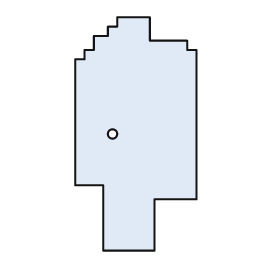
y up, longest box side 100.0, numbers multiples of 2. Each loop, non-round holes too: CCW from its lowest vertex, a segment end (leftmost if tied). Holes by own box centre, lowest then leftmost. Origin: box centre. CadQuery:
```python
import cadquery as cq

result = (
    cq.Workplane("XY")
    .moveTo(-14.0, -50.0)
    .lineTo(8.0, -50.0)
    .lineTo(8.0, -28.0)
    .lineTo(26.0, -28.0)
    .lineTo(26.0, 36.0)
    .lineTo(22.0, 36.0)
    .lineTo(22.0, 40.0)
    .lineTo(6.0, 40.0)
    .lineTo(6.0, 50.0)
    .lineTo(-8.0, 50.0)
    .lineTo(-8.0, 46.0)
    .lineTo(-12.0, 46.0)
    .lineTo(-12.0, 42.0)
    .lineTo(-18.0, 42.0)
    .lineTo(-18.0, 36.0)
    .lineTo(-22.0, 36.0)
    .lineTo(-22.0, 32.0)
    .lineTo(-26.0, 32.0)
    .lineTo(-26.0, -22.0)
    .lineTo(-14.0, -22.0)
    .close()
    .moveTo(-10.0, 0.0)
    .circle(2.0)
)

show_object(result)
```